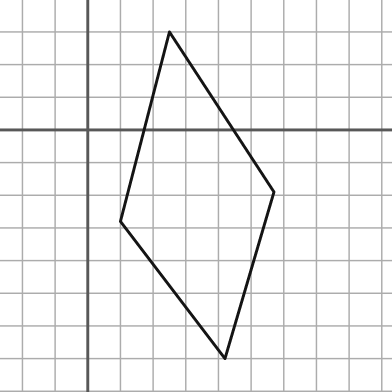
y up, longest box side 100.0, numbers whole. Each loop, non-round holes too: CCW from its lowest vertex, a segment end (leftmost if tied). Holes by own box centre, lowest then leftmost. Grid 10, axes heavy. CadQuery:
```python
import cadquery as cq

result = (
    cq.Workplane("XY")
    .moveTo(42.0, -70.0)
    .lineTo(57.0, -19.0)
    .lineTo(25.0, 30.0)
    .lineTo(10.0, -28.0)
    .close()
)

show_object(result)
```